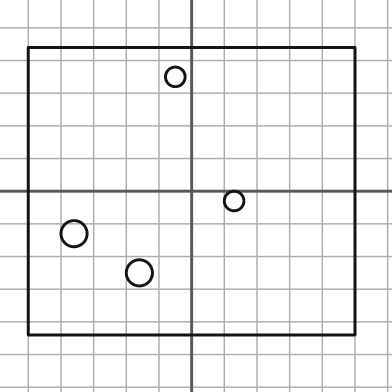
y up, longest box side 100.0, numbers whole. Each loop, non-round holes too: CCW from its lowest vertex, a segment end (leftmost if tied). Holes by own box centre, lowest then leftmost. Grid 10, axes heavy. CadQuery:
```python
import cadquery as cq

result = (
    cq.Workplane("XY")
    .moveTo(-50.0, -44.0)
    .lineTo(50.0, -44.0)
    .lineTo(50.0, 44.0)
    .lineTo(-50.0, 44.0)
    .close()
    .moveTo(-16.0, -25.0)
    .circle(4.0)
    .moveTo(-36.0, -13.0)
    .circle(4.0)
    .moveTo(13.0, -3.0)
    .circle(3.0)
    .moveTo(-5.0, 35.0)
    .circle(3.0)
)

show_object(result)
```